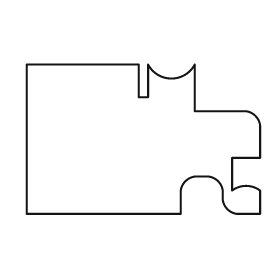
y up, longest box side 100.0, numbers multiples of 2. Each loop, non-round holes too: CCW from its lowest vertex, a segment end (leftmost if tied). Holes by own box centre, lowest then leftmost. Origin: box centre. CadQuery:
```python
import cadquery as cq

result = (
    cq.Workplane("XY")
    .moveTo(-50.0, -32.0)
    .lineTo(16.0, -32.0)
    .lineTo(16.0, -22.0)
    .threePointArc((18.0, -18.0), (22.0, -16.0))
    .lineTo(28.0, -16.0)
    .threePointArc((32.0, -18.0), (34.0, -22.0))
    .lineTo(34.0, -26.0)
    .threePointArc((36.0, -30.0), (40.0, -32.0))
    .lineTo(50.0, -32.0)
    .lineTo(50.0, -22.0)
    .threePointArc((44.0, -20.0), (38.0, -22.0))
    .lineTo(38.0, -8.0)
    .lineTo(50.0, -8.0)
    .lineTo(50.0, 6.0)
    .threePointArc((48.0, 10.0), (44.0, 12.0))
    .lineTo(22.0, 12.0)
    .lineTo(22.0, 32.0)
    .threePointArc((12.0, 26.0), (2.0, 32.0))
    .lineTo(2.0, 18.0)
    .lineTo(-2.0, 18.0)
    .lineTo(-2.0, 32.0)
    .lineTo(-50.0, 32.0)
    .close()
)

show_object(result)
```